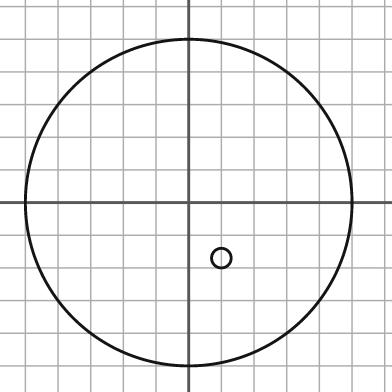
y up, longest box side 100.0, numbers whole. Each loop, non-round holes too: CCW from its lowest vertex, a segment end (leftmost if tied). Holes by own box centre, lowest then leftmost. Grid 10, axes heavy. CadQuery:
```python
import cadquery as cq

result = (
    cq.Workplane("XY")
    .moveTo(0.0, 0.0)
    .circle(50.0)
    .moveTo(10.0, -17.0)
    .circle(3.0)
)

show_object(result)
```